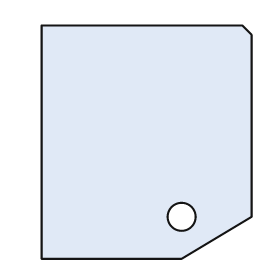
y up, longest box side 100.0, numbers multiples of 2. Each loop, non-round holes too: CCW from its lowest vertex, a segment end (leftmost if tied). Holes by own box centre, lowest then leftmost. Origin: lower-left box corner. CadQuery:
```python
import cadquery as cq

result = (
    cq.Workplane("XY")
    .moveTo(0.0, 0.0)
    .lineTo(60.0, 0.0)
    .lineTo(90.0, 18.0)
    .lineTo(90.0, 96.0)
    .lineTo(86.0, 100.0)
    .lineTo(0.0, 100.0)
    .close()
    .moveTo(60.0, 18.0)
    .circle(6.0)
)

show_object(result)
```